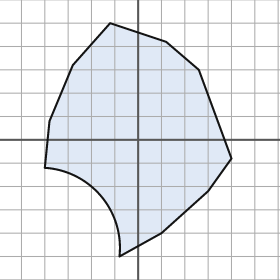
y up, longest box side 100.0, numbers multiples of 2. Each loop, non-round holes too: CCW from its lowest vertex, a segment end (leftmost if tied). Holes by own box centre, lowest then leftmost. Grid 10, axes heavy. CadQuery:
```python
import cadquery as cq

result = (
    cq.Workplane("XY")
    .moveTo(-8.0, -50.0)
    .lineTo(10.0, -40.0)
    .lineTo(30.0, -22.0)
    .lineTo(40.0, -8.0)
    .lineTo(26.0, 30.0)
    .lineTo(12.0, 42.0)
    .lineTo(-12.0, 50.0)
    .lineTo(-28.0, 32.0)
    .lineTo(-38.0, 8.0)
    .lineTo(-40.0, -12.0)
    .threePointArc((-16.0, -24.0), (-8.0, -50.0))
    .close()
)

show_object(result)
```